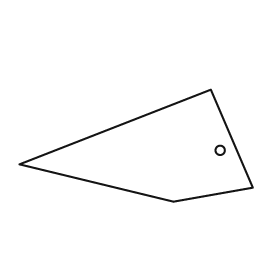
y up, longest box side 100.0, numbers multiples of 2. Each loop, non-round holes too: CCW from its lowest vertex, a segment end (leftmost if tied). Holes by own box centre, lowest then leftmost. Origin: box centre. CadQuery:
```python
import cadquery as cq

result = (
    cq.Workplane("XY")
    .moveTo(16.0, -24.0)
    .lineTo(50.0, -18.0)
    .lineTo(32.0, 24.0)
    .lineTo(-50.0, -8.0)
    .close()
    .moveTo(36.0, -2.0)
    .circle(2.0)
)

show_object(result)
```